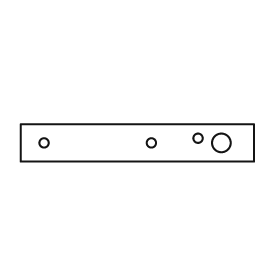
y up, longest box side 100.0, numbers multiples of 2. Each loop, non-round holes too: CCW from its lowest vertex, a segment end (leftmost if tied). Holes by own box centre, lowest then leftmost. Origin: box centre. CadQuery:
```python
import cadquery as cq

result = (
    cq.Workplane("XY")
    .moveTo(-50.0, -8.0)
    .lineTo(50.0, -8.0)
    .lineTo(50.0, 8.0)
    .lineTo(-50.0, 8.0)
    .close()
    .moveTo(-40.0, 0.0)
    .circle(2.0)
    .moveTo(6.0, 0.0)
    .circle(2.0)
    .moveTo(36.0, 0.0)
    .circle(4.0)
    .moveTo(26.0, 2.0)
    .circle(2.0)
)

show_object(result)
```